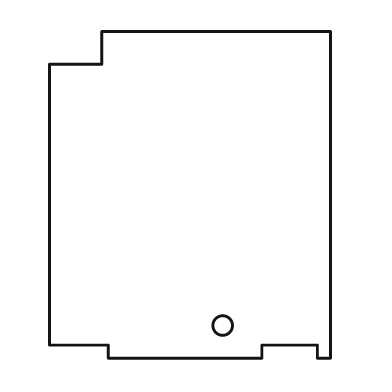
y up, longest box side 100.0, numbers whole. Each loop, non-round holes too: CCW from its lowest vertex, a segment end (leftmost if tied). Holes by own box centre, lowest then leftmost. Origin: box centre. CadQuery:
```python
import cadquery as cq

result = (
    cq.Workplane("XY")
    .moveTo(-25.0, -50.0)
    .lineTo(22.0, -50.0)
    .lineTo(22.0, -46.0)
    .lineTo(39.0, -46.0)
    .lineTo(39.0, -50.0)
    .lineTo(43.0, -50.0)
    .lineTo(43.0, 50.0)
    .lineTo(-27.0, 50.0)
    .lineTo(-27.0, 40.0)
    .lineTo(-43.0, 40.0)
    .lineTo(-43.0, -46.0)
    .lineTo(-25.0, -46.0)
    .close()
    .moveTo(10.0, -40.0)
    .circle(3.0)
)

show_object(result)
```